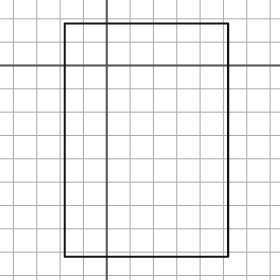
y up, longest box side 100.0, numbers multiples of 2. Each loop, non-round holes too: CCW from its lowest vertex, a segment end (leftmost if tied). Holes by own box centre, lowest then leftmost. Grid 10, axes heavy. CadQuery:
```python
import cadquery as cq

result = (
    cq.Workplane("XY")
    .moveTo(-18.0, -82.0)
    .lineTo(52.0, -82.0)
    .lineTo(52.0, 18.0)
    .lineTo(-18.0, 18.0)
    .close()
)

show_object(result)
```